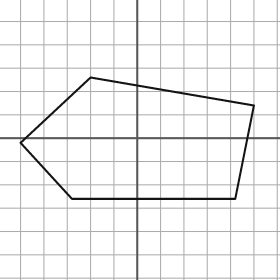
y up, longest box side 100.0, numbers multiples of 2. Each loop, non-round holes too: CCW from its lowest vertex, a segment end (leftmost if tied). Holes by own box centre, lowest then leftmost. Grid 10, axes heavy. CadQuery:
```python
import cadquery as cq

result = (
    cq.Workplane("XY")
    .moveTo(-28.0, -26.0)
    .lineTo(42.0, -26.0)
    .lineTo(50.0, 14.0)
    .lineTo(-20.0, 26.0)
    .lineTo(-50.0, -2.0)
    .close()
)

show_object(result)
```